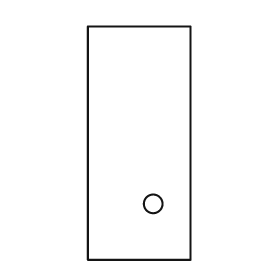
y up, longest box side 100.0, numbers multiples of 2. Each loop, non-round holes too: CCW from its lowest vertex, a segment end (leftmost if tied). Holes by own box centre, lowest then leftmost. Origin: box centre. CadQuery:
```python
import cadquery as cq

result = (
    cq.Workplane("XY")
    .moveTo(-22.0, -50.0)
    .lineTo(22.0, -50.0)
    .lineTo(22.0, 50.0)
    .lineTo(-22.0, 50.0)
    .close()
    .moveTo(6.0, -26.0)
    .circle(4.0)
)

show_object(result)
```